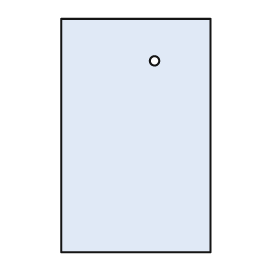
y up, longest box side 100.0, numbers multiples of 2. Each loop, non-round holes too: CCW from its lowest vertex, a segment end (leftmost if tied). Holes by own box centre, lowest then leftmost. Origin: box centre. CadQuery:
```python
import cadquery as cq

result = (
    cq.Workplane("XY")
    .moveTo(-32.0, -50.0)
    .lineTo(32.0, -50.0)
    .lineTo(32.0, 50.0)
    .lineTo(-32.0, 50.0)
    .close()
    .moveTo(8.0, 32.0)
    .circle(2.0)
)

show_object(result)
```